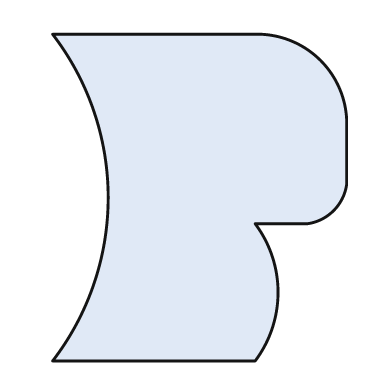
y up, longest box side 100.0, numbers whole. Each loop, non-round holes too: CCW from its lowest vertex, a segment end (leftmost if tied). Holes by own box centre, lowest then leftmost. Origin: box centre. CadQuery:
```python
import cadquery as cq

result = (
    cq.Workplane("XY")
    .moveTo(-45.0, -50.0)
    .lineTo(17.0, -50.0)
    .threePointArc((24.0, -29.0), (17.0, -8.0))
    .lineTo(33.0, -8.0)
    .threePointArc((41.0, -4.0), (45.0, 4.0))
    .lineTo(45.0, 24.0)
    .threePointArc((37.0, 42.0), (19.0, 50.0))
    .lineTo(-45.0, 50.0)
    .threePointArc((-28.0, 0.0), (-45.0, -50.0))
    .close()
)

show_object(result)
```